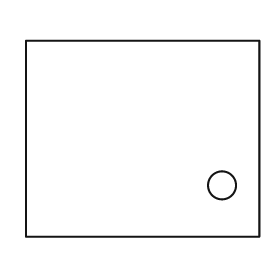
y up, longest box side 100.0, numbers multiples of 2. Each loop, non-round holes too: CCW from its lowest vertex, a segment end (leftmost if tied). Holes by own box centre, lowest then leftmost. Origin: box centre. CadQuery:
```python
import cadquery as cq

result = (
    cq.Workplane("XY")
    .moveTo(-50.0, -42.0)
    .lineTo(50.0, -42.0)
    .lineTo(50.0, 42.0)
    .lineTo(-50.0, 42.0)
    .close()
    .moveTo(34.0, -20.0)
    .circle(6.0)
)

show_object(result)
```